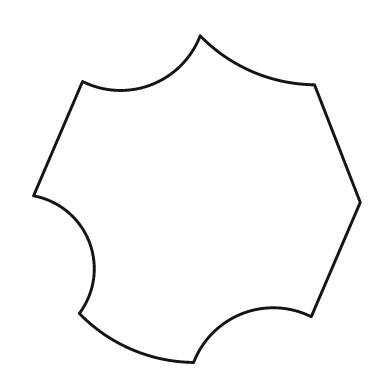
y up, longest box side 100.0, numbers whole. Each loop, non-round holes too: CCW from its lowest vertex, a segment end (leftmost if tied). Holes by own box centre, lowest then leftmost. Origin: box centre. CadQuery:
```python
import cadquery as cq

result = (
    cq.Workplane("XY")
    .moveTo(-1.0, -50.0)
    .threePointArc((14.0, -35.0), (35.0, -36.0))
    .lineTo(50.0, -1.0)
    .lineTo(36.0, 35.0)
    .threePointArc((17.0, 39.0), (1.0, 50.0))
    .threePointArc((-14.0, 35.0), (-35.0, 36.0))
    .lineTo(-50.0, 1.0)
    .threePointArc((-33.0, -13.0), (-36.0, -35.0))
    .threePointArc((-20.0, -46.0), (-1.0, -50.0))
    .close()
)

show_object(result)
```